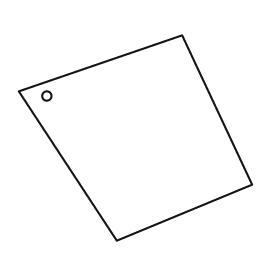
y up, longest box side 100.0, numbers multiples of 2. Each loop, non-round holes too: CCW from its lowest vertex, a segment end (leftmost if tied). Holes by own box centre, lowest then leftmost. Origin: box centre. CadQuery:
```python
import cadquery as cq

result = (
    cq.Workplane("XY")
    .moveTo(-8.0, -44.0)
    .lineTo(50.0, -20.0)
    .lineTo(20.0, 44.0)
    .lineTo(-50.0, 20.0)
    .close()
    .moveTo(-38.0, 18.0)
    .circle(2.0)
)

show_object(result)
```